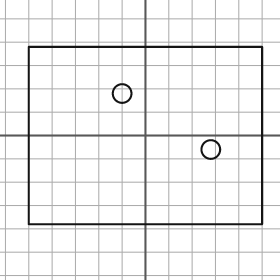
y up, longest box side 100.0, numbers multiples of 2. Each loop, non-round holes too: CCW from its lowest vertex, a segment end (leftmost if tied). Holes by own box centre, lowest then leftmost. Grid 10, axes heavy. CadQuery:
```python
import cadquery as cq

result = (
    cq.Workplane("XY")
    .moveTo(-50.0, -38.0)
    .lineTo(50.0, -38.0)
    .lineTo(50.0, 38.0)
    .lineTo(-50.0, 38.0)
    .close()
    .moveTo(28.0, -6.0)
    .circle(4.0)
    .moveTo(-10.0, 18.0)
    .circle(4.0)
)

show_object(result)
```